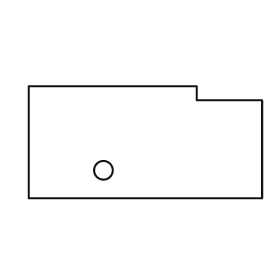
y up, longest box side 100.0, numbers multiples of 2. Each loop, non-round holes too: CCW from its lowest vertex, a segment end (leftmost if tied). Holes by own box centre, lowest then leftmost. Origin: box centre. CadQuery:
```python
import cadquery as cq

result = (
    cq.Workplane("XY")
    .moveTo(-50.0, -24.0)
    .lineTo(50.0, -24.0)
    .lineTo(50.0, 18.0)
    .lineTo(22.0, 18.0)
    .lineTo(22.0, 24.0)
    .lineTo(-50.0, 24.0)
    .close()
    .moveTo(-18.0, -12.0)
    .circle(4.0)
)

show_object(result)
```